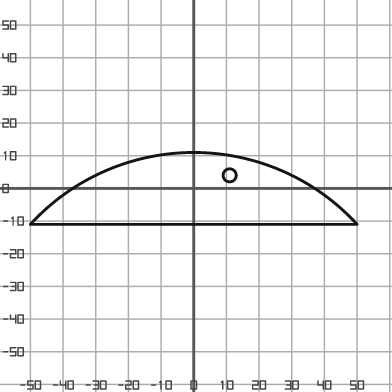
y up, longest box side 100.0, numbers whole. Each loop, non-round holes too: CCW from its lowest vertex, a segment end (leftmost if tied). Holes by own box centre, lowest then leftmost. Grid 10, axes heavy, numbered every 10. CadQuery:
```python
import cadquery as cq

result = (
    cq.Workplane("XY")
    .moveTo(-50.0, -11.0)
    .lineTo(50.0, -11.0)
    .threePointArc((0.0, 11.0), (-50.0, -11.0))
    .close()
    .moveTo(11.0, 4.0)
    .circle(2.0)
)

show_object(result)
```